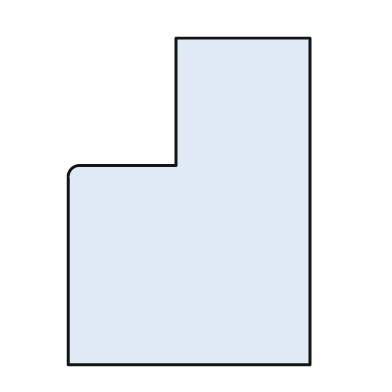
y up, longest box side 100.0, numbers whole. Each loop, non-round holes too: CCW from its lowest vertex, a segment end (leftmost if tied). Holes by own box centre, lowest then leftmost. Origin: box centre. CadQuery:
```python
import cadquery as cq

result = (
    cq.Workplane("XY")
    .moveTo(-37.0, -50.0)
    .lineTo(37.0, -50.0)
    .lineTo(37.0, 50.0)
    .lineTo(-4.0, 50.0)
    .lineTo(-4.0, 11.0)
    .lineTo(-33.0, 11.0)
    .threePointArc((-36.0, 10.0), (-37.0, 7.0))
    .close()
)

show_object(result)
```